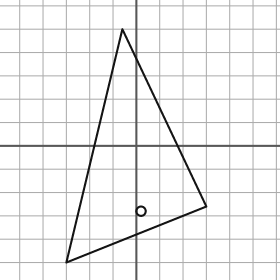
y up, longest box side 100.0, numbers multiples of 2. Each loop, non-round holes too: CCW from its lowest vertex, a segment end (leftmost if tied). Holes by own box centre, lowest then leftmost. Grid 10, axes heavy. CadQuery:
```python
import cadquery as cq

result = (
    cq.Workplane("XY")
    .moveTo(-30.0, -50.0)
    .lineTo(30.0, -26.0)
    .lineTo(-6.0, 50.0)
    .close()
    .moveTo(2.0, -28.0)
    .circle(2.0)
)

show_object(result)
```